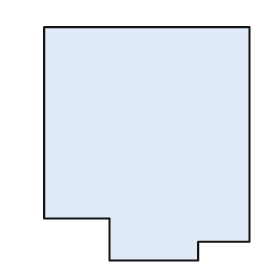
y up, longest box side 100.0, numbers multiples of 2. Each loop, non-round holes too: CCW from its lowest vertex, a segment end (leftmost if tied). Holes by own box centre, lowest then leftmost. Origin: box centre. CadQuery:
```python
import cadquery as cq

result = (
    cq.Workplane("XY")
    .moveTo(-16.0, -50.0)
    .lineTo(22.0, -50.0)
    .lineTo(22.0, -42.0)
    .lineTo(44.0, -42.0)
    .lineTo(44.0, 50.0)
    .lineTo(-44.0, 50.0)
    .lineTo(-44.0, -32.0)
    .lineTo(-16.0, -32.0)
    .close()
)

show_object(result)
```